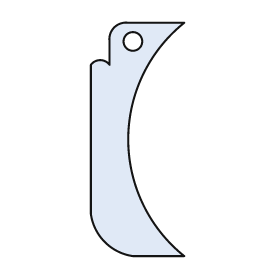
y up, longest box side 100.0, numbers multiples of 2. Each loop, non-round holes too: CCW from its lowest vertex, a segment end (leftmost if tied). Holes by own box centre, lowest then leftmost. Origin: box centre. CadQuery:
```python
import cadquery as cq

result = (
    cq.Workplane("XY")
    .moveTo(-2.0, -50.0)
    .lineTo(20.0, -50.0)
    .threePointArc((-4.0, 0.0), (20.0, 50.0))
    .lineTo(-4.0, 50.0)
    .threePointArc((-10.0, 48.0), (-12.0, 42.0))
    .lineTo(-12.0, 32.0)
    .threePointArc((-16.0, 34.0), (-20.0, 32.0))
    .lineTo(-20.0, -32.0)
    .threePointArc((-14.0, -44.0), (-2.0, -50.0))
    .close()
    .moveTo(-2.0, 42.0)
    .circle(4.0)
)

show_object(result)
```